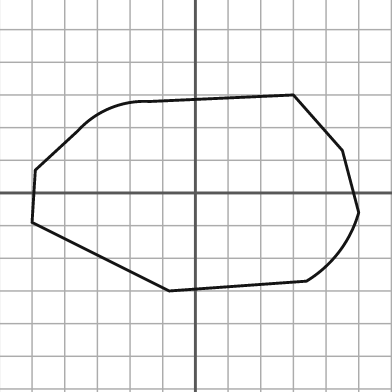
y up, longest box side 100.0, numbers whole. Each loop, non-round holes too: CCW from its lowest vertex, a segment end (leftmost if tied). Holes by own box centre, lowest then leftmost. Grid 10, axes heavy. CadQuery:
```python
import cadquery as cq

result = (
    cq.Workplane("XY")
    .moveTo(-8.0, -30.0)
    .lineTo(34.0, -27.0)
    .threePointArc((44.0, -18.0), (50.0, -6.0))
    .lineTo(45.0, 13.0)
    .lineTo(30.0, 30.0)
    .lineTo(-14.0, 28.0)
    .threePointArc((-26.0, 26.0), (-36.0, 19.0))
    .lineTo(-49.0, 7.0)
    .lineTo(-50.0, -9.0)
    .close()
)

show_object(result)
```